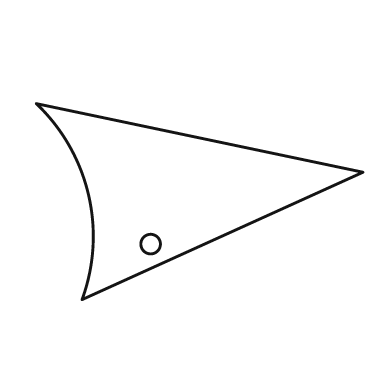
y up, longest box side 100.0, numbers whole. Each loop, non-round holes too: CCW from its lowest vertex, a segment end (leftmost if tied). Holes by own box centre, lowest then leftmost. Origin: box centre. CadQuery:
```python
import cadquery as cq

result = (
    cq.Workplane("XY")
    .moveTo(-36.0, -30.0)
    .lineTo(50.0, 9.0)
    .lineTo(-50.0, 30.0)
    .threePointArc((-34.0, 2.0), (-36.0, -30.0))
    .close()
    .moveTo(-15.0, -13.0)
    .circle(3.0)
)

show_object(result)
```